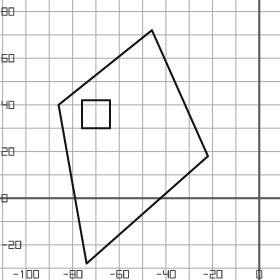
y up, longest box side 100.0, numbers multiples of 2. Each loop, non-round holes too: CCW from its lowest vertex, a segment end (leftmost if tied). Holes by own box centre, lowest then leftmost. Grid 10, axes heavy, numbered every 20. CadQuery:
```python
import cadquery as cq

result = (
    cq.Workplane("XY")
    .moveTo(-74.0, -28.0)
    .lineTo(-22.0, 18.0)
    .lineTo(-46.0, 72.0)
    .lineTo(-86.0, 40.0)
    .close()
    .moveTo(-76.0, 30.0)
    .lineTo(-64.0, 30.0)
    .lineTo(-64.0, 42.0)
    .lineTo(-76.0, 42.0)
    .close()
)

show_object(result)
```